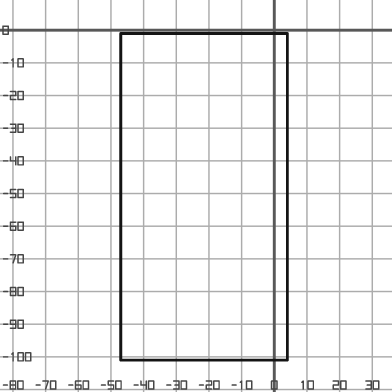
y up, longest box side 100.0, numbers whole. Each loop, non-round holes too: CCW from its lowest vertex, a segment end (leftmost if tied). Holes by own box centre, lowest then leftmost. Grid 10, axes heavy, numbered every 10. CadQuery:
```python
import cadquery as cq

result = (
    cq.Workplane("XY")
    .moveTo(-47.0, -101.0)
    .lineTo(4.0, -101.0)
    .lineTo(4.0, -1.0)
    .lineTo(-47.0, -1.0)
    .close()
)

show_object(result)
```